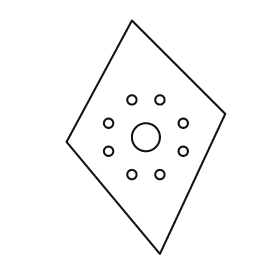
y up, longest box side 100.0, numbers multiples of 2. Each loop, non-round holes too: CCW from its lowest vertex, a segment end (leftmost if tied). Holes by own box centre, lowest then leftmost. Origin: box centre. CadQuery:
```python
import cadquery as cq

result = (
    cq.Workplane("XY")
    .moveTo(6.0, -50.0)
    .lineTo(34.0, 10.0)
    .lineTo(-6.0, 50.0)
    .lineTo(-34.0, -2.0)
    .close()
    .moveTo(-6.0, -16.0)
    .circle(2.0)
    .moveTo(6.0, -16.0)
    .circle(2.0)
    .moveTo(-16.0, -6.0)
    .circle(2.0)
    .moveTo(16.0, -6.0)
    .circle(2.0)
    .moveTo(0.0, 0.0)
    .circle(6.0)
    .moveTo(-16.0, 6.0)
    .circle(2.0)
    .moveTo(16.0, 6.0)
    .circle(2.0)
    .moveTo(-6.0, 16.0)
    .circle(2.0)
    .moveTo(6.0, 16.0)
    .circle(2.0)
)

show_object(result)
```